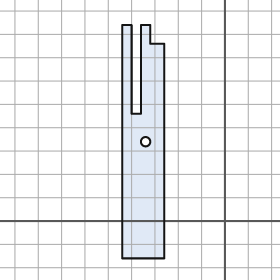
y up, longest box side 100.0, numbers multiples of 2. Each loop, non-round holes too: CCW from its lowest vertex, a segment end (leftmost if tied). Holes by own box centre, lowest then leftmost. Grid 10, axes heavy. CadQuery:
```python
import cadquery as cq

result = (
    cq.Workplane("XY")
    .moveTo(-44.0, -16.0)
    .lineTo(-26.0, -16.0)
    .lineTo(-26.0, 76.0)
    .lineTo(-32.0, 76.0)
    .lineTo(-32.0, 84.0)
    .lineTo(-36.0, 84.0)
    .lineTo(-36.0, 46.0)
    .lineTo(-40.0, 46.0)
    .lineTo(-40.0, 84.0)
    .lineTo(-44.0, 84.0)
    .close()
    .moveTo(-34.0, 34.0)
    .circle(2.0)
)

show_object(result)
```